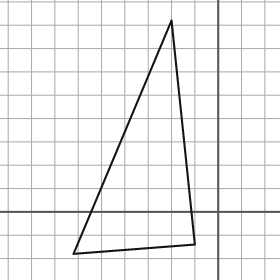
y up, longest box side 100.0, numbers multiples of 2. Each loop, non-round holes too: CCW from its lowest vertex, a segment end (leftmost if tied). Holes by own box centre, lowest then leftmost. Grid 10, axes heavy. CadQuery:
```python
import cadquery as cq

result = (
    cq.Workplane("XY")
    .moveTo(-62.0, -18.0)
    .lineTo(-10.0, -14.0)
    .lineTo(-20.0, 82.0)
    .close()
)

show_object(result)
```